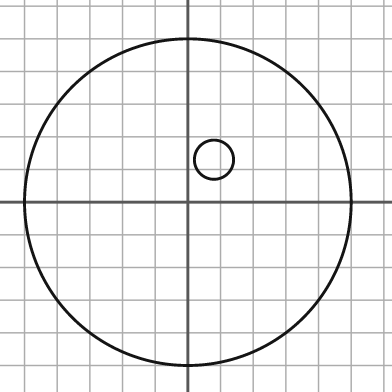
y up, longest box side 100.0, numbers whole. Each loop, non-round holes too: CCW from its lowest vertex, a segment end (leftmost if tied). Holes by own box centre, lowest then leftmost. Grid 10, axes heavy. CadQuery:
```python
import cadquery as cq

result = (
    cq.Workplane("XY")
    .moveTo(0.0, 0.0)
    .circle(50.0)
    .moveTo(8.0, 13.0)
    .circle(6.0)
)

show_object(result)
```